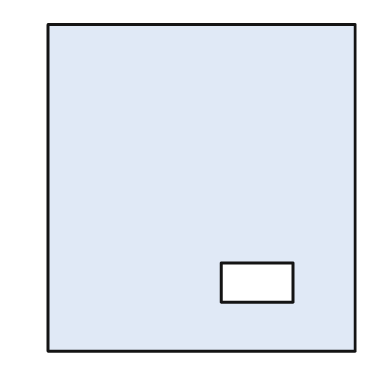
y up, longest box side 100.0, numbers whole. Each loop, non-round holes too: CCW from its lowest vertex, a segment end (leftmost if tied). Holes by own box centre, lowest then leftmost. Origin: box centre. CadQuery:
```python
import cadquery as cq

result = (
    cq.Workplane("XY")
    .moveTo(-47.0, -50.0)
    .lineTo(47.0, -50.0)
    .lineTo(47.0, 50.0)
    .lineTo(-47.0, 50.0)
    .close()
    .moveTo(6.0, -35.0)
    .lineTo(28.0, -35.0)
    .lineTo(28.0, -23.0)
    .lineTo(6.0, -23.0)
    .close()
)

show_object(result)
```